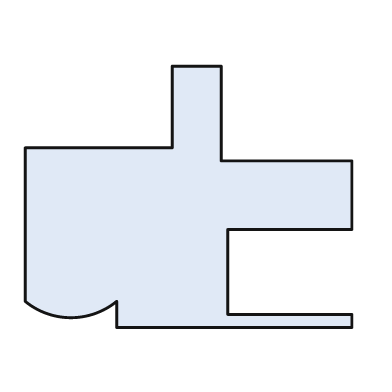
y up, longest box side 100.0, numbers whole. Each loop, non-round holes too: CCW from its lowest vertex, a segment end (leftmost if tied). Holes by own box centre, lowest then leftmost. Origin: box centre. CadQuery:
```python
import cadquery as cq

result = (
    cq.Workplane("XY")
    .moveTo(-22.0, -40.0)
    .lineTo(50.0, -40.0)
    .lineTo(50.0, -36.0)
    .lineTo(12.0, -36.0)
    .lineTo(12.0, -10.0)
    .lineTo(50.0, -10.0)
    .lineTo(50.0, 11.0)
    .lineTo(10.0, 11.0)
    .lineTo(10.0, 40.0)
    .lineTo(-5.0, 40.0)
    .lineTo(-5.0, 15.0)
    .lineTo(-50.0, 15.0)
    .lineTo(-50.0, -32.0)
    .threePointArc((-36.0, -37.0), (-22.0, -32.0))
    .close()
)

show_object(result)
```